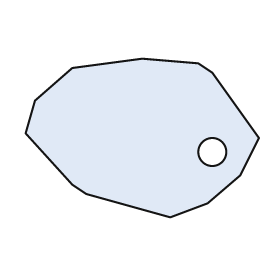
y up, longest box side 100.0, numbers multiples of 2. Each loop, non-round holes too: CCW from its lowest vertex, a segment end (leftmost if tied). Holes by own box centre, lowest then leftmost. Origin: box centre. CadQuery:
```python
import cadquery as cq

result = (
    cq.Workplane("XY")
    .moveTo(12.0, -34.0)
    .lineTo(28.0, -28.0)
    .lineTo(42.0, -16.0)
    .lineTo(50.0, 0.0)
    .lineTo(30.0, 28.0)
    .lineTo(24.0, 32.0)
    .lineTo(0.0, 34.0)
    .lineTo(-30.0, 30.0)
    .lineTo(-46.0, 16.0)
    .lineTo(-50.0, 2.0)
    .lineTo(-30.0, -20.0)
    .lineTo(-24.0, -24.0)
    .close()
    .moveTo(30.0, -6.0)
    .circle(6.0)
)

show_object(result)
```